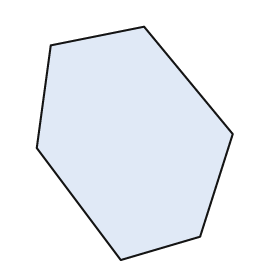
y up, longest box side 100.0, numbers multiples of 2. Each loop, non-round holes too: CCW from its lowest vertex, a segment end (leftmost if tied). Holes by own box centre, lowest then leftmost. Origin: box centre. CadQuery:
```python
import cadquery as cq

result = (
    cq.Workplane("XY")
    .moveTo(-6.0, -50.0)
    .lineTo(28.0, -40.0)
    .lineTo(42.0, 4.0)
    .lineTo(4.0, 50.0)
    .lineTo(-36.0, 42.0)
    .lineTo(-42.0, -2.0)
    .close()
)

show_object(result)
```